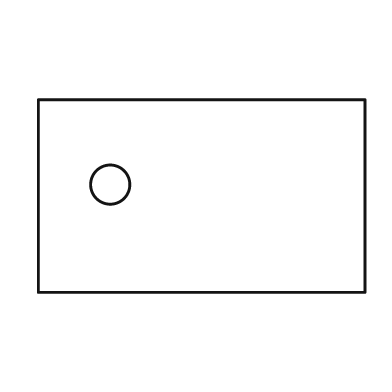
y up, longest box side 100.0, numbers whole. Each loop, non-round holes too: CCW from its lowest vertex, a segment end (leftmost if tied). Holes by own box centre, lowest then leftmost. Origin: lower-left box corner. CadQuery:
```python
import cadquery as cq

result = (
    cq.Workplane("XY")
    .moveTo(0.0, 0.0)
    .lineTo(100.0, 0.0)
    .lineTo(100.0, 59.0)
    .lineTo(0.0, 59.0)
    .close()
    .moveTo(22.0, 33.0)
    .circle(6.0)
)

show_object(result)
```